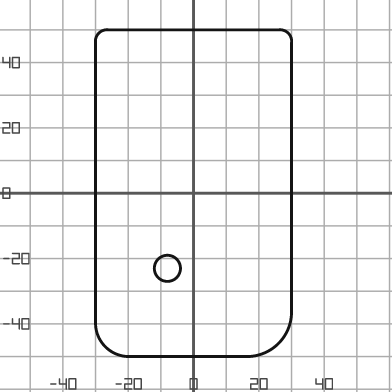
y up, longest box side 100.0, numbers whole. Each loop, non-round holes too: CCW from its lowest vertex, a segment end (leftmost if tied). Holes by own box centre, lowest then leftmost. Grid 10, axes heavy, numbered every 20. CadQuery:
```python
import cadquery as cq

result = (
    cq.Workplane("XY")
    .moveTo(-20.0, -50.0)
    .lineTo(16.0, -50.0)
    .threePointArc((26.0, -46.0), (30.0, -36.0))
    .lineTo(30.0, 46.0)
    .threePointArc((29.0, 49.0), (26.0, 50.0))
    .lineTo(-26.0, 50.0)
    .threePointArc((-29.0, 49.0), (-30.0, 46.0))
    .lineTo(-30.0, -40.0)
    .threePointArc((-27.0, -47.0), (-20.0, -50.0))
    .close()
    .moveTo(-8.0, -23.0)
    .circle(4.0)
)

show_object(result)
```